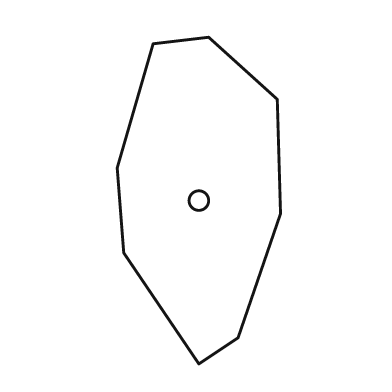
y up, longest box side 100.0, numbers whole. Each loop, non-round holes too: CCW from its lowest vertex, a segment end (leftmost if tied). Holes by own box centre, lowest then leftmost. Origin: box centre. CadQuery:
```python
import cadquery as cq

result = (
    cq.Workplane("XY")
    .moveTo(0.0, -50.0)
    .lineTo(12.0, -42.0)
    .lineTo(25.0, -4.0)
    .lineTo(24.0, 31.0)
    .lineTo(3.0, 50.0)
    .lineTo(-14.0, 48.0)
    .lineTo(-25.0, 10.0)
    .lineTo(-23.0, -16.0)
    .close()
    .moveTo(0.0, 0.0)
    .circle(3.0)
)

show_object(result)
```